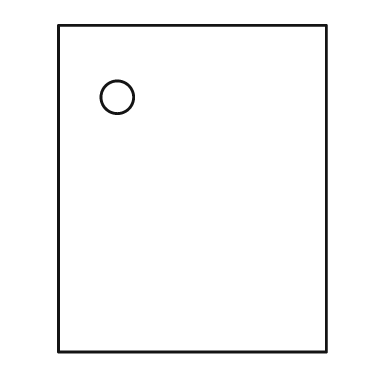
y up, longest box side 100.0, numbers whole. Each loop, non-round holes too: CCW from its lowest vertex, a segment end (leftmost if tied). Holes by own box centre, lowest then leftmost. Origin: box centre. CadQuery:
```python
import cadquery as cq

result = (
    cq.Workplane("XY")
    .moveTo(-41.0, -50.0)
    .lineTo(41.0, -50.0)
    .lineTo(41.0, 50.0)
    .lineTo(-41.0, 50.0)
    .close()
    .moveTo(-23.0, 28.0)
    .circle(5.0)
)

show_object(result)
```